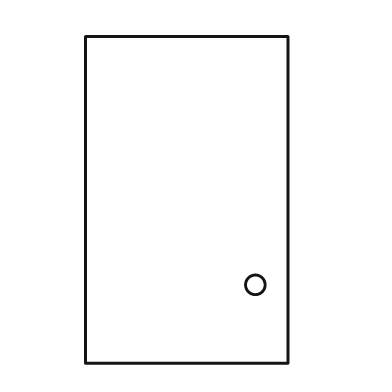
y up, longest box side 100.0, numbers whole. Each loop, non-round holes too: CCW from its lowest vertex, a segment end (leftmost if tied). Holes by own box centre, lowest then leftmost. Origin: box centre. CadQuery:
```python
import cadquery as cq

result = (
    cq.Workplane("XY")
    .moveTo(-31.0, -50.0)
    .lineTo(31.0, -50.0)
    .lineTo(31.0, 50.0)
    .lineTo(-31.0, 50.0)
    .close()
    .moveTo(21.0, -26.0)
    .circle(3.0)
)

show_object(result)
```